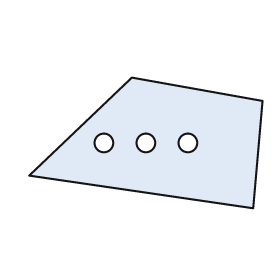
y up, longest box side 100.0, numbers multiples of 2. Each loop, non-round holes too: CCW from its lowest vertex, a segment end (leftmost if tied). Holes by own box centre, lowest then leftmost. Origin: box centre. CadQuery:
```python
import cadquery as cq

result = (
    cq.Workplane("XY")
    .moveTo(46.0, -28.0)
    .lineTo(50.0, 18.0)
    .lineTo(-6.0, 28.0)
    .lineTo(-50.0, -14.0)
    .close()
    .moveTo(-18.0, 0.0)
    .circle(4.0)
    .moveTo(0.0, 0.0)
    .circle(4.0)
    .moveTo(18.0, 0.0)
    .circle(4.0)
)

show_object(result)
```